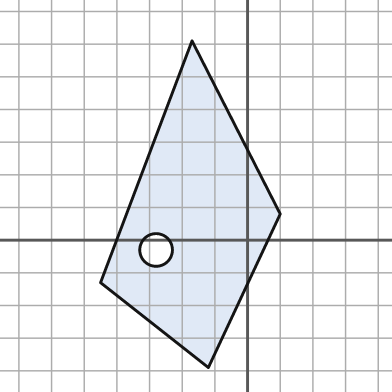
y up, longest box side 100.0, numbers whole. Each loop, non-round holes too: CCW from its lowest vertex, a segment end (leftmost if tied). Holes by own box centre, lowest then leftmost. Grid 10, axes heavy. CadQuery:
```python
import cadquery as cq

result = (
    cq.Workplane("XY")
    .moveTo(-12.0, -39.0)
    .lineTo(10.0, 8.0)
    .lineTo(-17.0, 61.0)
    .lineTo(-45.0, -13.0)
    .close()
    .moveTo(-28.0, -3.0)
    .circle(5.0)
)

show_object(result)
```